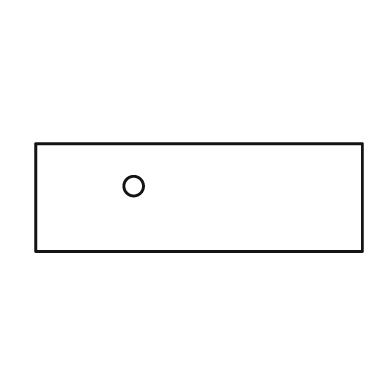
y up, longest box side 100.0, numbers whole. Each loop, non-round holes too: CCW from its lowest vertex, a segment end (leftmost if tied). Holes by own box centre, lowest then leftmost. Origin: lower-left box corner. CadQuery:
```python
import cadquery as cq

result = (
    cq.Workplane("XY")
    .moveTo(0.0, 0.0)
    .lineTo(100.0, 0.0)
    .lineTo(100.0, 33.0)
    .lineTo(0.0, 33.0)
    .close()
    .moveTo(30.0, 20.0)
    .circle(3.0)
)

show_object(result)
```